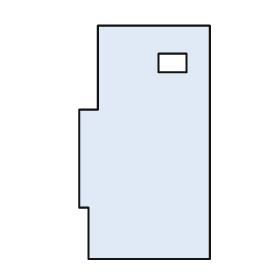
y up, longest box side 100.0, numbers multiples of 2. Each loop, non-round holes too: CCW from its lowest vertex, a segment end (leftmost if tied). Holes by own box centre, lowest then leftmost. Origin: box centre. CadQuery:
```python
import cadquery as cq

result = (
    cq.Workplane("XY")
    .moveTo(-24.0, -50.0)
    .lineTo(28.0, -50.0)
    .lineTo(28.0, 50.0)
    .lineTo(-20.0, 50.0)
    .lineTo(-20.0, 14.0)
    .lineTo(-28.0, 14.0)
    .lineTo(-28.0, -28.0)
    .lineTo(-24.0, -28.0)
    .close()
    .moveTo(6.0, 30.0)
    .lineTo(18.0, 30.0)
    .lineTo(18.0, 38.0)
    .lineTo(6.0, 38.0)
    .close()
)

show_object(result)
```